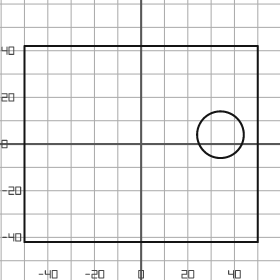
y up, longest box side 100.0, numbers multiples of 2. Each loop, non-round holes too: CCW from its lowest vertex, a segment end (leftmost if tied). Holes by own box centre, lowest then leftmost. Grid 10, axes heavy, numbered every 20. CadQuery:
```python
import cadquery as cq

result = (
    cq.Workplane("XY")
    .moveTo(-50.0, -42.0)
    .lineTo(50.0, -42.0)
    .lineTo(50.0, 42.0)
    .lineTo(-50.0, 42.0)
    .close()
    .moveTo(34.0, 4.0)
    .circle(10.0)
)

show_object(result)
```